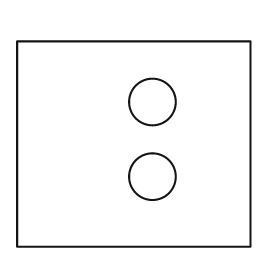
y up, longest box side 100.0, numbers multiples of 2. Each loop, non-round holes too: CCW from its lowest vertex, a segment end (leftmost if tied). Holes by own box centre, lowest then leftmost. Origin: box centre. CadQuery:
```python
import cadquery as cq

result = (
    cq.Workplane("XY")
    .moveTo(-50.0, -44.0)
    .lineTo(50.0, -44.0)
    .lineTo(50.0, 44.0)
    .lineTo(-50.0, 44.0)
    .close()
    .moveTo(8.0, -14.0)
    .circle(10.0)
    .moveTo(8.0, 18.0)
    .circle(10.0)
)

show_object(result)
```